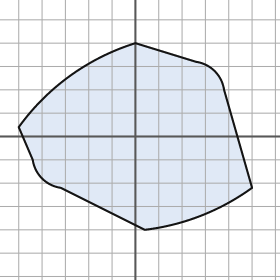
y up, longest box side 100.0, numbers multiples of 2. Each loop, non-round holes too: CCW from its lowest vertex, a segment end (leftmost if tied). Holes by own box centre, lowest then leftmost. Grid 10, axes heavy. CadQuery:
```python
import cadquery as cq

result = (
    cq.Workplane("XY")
    .moveTo(4.0, -40.0)
    .threePointArc((28.0, -34.0), (50.0, -22.0))
    .lineTo(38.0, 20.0)
    .threePointArc((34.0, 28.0), (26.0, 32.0))
    .lineTo(0.0, 40.0)
    .threePointArc((-28.0, 26.0), (-50.0, 4.0))
    .lineTo(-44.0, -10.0)
    .threePointArc((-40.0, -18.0), (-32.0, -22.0))
    .close()
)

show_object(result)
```